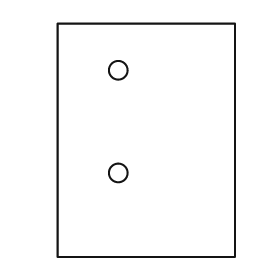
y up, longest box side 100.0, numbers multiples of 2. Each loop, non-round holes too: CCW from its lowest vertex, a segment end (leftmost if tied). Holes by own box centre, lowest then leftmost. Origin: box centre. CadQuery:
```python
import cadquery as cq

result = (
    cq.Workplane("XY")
    .moveTo(-38.0, -50.0)
    .lineTo(38.0, -50.0)
    .lineTo(38.0, 50.0)
    .lineTo(-38.0, 50.0)
    .close()
    .moveTo(-12.0, -14.0)
    .circle(4.0)
    .moveTo(-12.0, 30.0)
    .circle(4.0)
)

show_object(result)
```